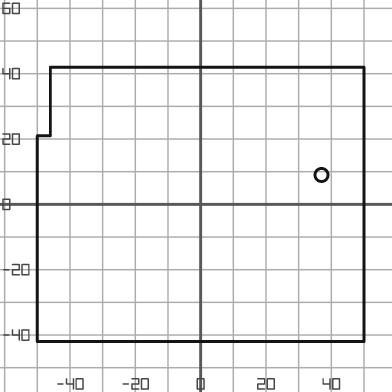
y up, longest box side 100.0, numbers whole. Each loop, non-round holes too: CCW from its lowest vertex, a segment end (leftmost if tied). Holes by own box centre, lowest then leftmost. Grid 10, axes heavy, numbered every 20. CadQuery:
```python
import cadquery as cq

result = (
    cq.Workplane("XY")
    .moveTo(-50.0, -42.0)
    .lineTo(50.0, -42.0)
    .lineTo(50.0, 42.0)
    .lineTo(-46.0, 42.0)
    .lineTo(-46.0, 21.0)
    .lineTo(-50.0, 21.0)
    .close()
    .moveTo(37.0, 9.0)
    .circle(2.0)
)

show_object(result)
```